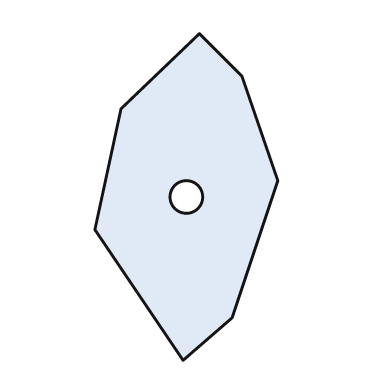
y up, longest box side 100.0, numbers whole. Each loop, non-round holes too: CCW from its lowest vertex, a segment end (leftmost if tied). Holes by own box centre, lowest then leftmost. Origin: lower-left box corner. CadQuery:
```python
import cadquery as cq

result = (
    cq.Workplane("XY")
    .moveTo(27.0, 0.0)
    .lineTo(42.0, 13.0)
    .lineTo(56.0, 55.0)
    .lineTo(45.0, 87.0)
    .lineTo(32.0, 100.0)
    .lineTo(8.0, 77.0)
    .lineTo(0.0, 40.0)
    .close()
    .moveTo(28.0, 50.0)
    .circle(5.0)
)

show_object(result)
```